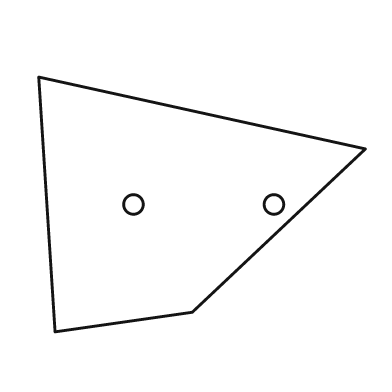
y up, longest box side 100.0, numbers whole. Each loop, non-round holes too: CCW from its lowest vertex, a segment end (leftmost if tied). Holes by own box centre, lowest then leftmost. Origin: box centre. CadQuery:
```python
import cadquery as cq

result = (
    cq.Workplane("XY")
    .moveTo(-45.0, -39.0)
    .lineTo(-3.0, -33.0)
    .lineTo(50.0, 17.0)
    .lineTo(-50.0, 39.0)
    .close()
    .moveTo(-21.0, 0.0)
    .circle(3.0)
    .moveTo(22.0, 0.0)
    .circle(3.0)
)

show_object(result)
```